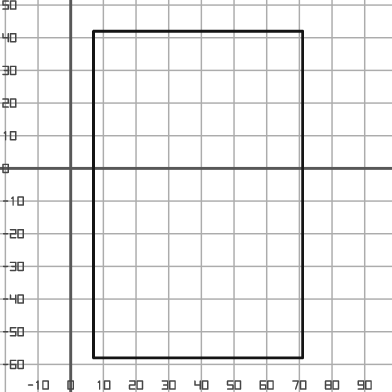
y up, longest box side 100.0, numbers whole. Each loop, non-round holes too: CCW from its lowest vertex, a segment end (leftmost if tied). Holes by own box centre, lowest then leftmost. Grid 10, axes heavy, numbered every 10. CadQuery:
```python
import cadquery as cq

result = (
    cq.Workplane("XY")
    .moveTo(7.0, -58.0)
    .lineTo(71.0, -58.0)
    .lineTo(71.0, 42.0)
    .lineTo(7.0, 42.0)
    .close()
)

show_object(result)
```